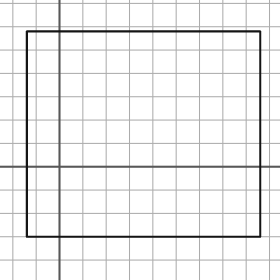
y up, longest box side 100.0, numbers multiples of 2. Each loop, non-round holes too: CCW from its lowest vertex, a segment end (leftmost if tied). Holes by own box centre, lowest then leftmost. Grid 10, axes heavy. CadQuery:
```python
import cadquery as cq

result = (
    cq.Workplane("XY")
    .moveTo(-14.0, -30.0)
    .lineTo(86.0, -30.0)
    .lineTo(86.0, 58.0)
    .lineTo(-14.0, 58.0)
    .close()
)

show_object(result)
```